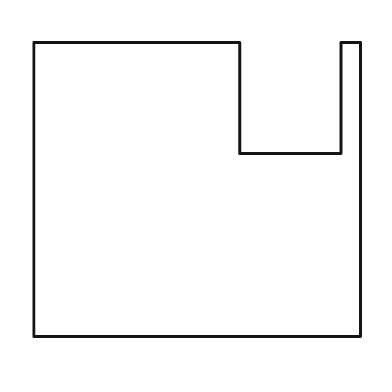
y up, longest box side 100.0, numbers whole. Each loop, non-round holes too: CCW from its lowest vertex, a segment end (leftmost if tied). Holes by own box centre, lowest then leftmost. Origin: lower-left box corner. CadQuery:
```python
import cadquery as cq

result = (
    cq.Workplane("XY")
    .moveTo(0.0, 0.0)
    .lineTo(100.0, 0.0)
    .lineTo(100.0, 90.0)
    .lineTo(94.0, 90.0)
    .lineTo(94.0, 56.0)
    .lineTo(63.0, 56.0)
    .lineTo(63.0, 90.0)
    .lineTo(0.0, 90.0)
    .close()
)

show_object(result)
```